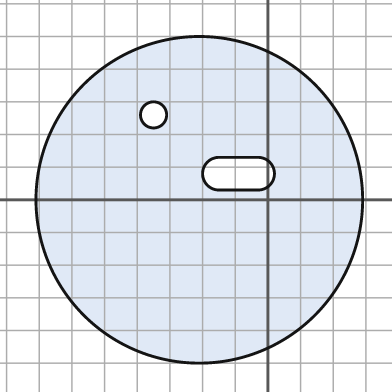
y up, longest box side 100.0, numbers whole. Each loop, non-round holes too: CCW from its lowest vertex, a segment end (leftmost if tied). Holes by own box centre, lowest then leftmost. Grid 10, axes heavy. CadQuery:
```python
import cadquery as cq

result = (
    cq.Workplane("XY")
    .moveTo(-21.0, 0.0)
    .circle(50.0)
    .moveTo(-15.0, 3.0)
    .lineTo(-3.0, 3.0)
    .threePointArc((2.0, 8.0), (-3.0, 13.0))
    .lineTo(-15.0, 13.0)
    .threePointArc((-20.0, 8.0), (-15.0, 3.0))
    .close()
    .moveTo(-35.0, 26.0)
    .circle(4.0)
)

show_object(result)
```